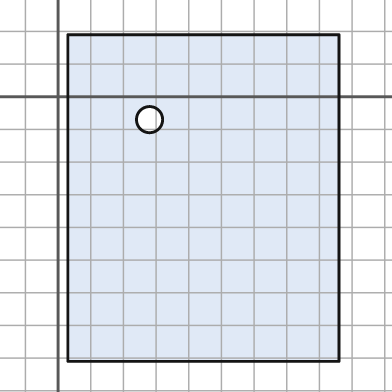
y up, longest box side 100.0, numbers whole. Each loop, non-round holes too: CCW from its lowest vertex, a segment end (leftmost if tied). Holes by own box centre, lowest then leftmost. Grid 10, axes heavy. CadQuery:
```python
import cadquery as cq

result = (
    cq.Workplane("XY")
    .moveTo(3.0, -81.0)
    .lineTo(86.0, -81.0)
    .lineTo(86.0, 19.0)
    .lineTo(3.0, 19.0)
    .close()
    .moveTo(28.0, -7.0)
    .circle(4.0)
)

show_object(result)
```